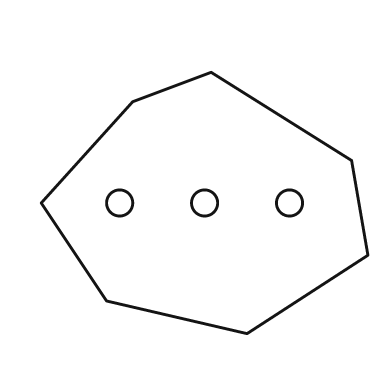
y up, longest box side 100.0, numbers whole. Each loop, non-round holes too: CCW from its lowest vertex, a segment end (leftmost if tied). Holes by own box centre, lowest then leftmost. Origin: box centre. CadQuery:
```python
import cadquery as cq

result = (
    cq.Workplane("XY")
    .moveTo(13.0, -40.0)
    .lineTo(50.0, -16.0)
    .lineTo(45.0, 13.0)
    .lineTo(2.0, 40.0)
    .lineTo(-22.0, 31.0)
    .lineTo(-50.0, 0.0)
    .lineTo(-30.0, -30.0)
    .close()
    .moveTo(-26.0, 0.0)
    .circle(4.0)
    .moveTo(0.0, 0.0)
    .circle(4.0)
    .moveTo(26.0, 0.0)
    .circle(4.0)
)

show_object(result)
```